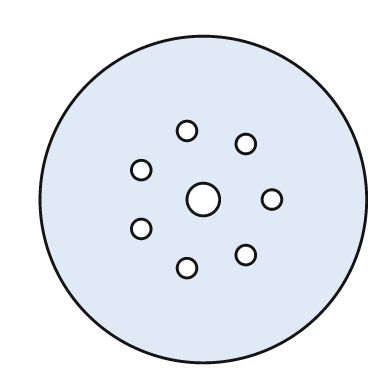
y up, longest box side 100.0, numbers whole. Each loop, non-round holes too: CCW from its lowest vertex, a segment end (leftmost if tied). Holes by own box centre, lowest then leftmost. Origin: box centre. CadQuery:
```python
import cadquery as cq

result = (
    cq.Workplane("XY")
    .moveTo(0.0, 0.0)
    .circle(50.0)
    .moveTo(-5.0, -21.0)
    .circle(3.0)
    .moveTo(13.0, -17.0)
    .circle(3.0)
    .moveTo(-19.0, -9.0)
    .circle(3.0)
    .moveTo(0.0, 0.0)
    .circle(5.0)
    .moveTo(21.0, 0.0)
    .circle(3.0)
    .moveTo(-19.0, 9.0)
    .circle(3.0)
    .moveTo(13.0, 17.0)
    .circle(3.0)
    .moveTo(-5.0, 21.0)
    .circle(3.0)
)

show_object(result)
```